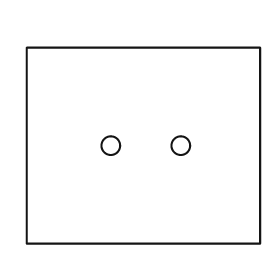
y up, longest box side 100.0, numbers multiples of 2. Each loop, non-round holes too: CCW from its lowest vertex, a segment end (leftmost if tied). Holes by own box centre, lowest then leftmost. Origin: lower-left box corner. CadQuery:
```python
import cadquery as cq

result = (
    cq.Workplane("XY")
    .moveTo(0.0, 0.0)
    .lineTo(100.0, 0.0)
    .lineTo(100.0, 84.0)
    .lineTo(0.0, 84.0)
    .close()
    .moveTo(36.0, 42.0)
    .circle(4.0)
    .moveTo(66.0, 42.0)
    .circle(4.0)
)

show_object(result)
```